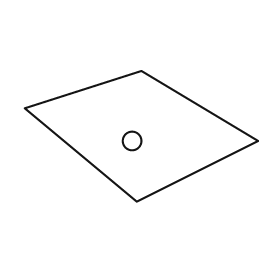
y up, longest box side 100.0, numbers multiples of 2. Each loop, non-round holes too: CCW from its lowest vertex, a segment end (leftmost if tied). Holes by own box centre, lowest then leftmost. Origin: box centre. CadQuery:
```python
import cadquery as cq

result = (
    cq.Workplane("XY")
    .moveTo(-2.0, -28.0)
    .lineTo(50.0, -2.0)
    .lineTo(0.0, 28.0)
    .lineTo(-50.0, 12.0)
    .close()
    .moveTo(-4.0, -2.0)
    .circle(4.0)
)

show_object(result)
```